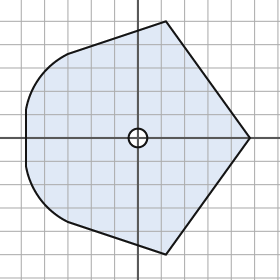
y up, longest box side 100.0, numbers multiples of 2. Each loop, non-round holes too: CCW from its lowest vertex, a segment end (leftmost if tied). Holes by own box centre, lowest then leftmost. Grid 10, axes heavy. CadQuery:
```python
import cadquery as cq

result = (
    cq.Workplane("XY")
    .moveTo(12.0, -50.0)
    .lineTo(48.0, 0.0)
    .lineTo(12.0, 50.0)
    .lineTo(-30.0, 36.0)
    .threePointArc((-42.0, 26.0), (-48.0, 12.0))
    .lineTo(-48.0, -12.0)
    .threePointArc((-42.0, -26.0), (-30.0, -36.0))
    .close()
    .moveTo(0.0, 0.0)
    .circle(4.0)
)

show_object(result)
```